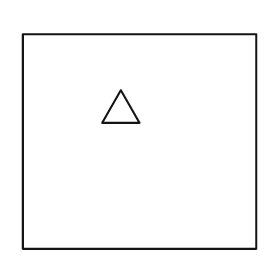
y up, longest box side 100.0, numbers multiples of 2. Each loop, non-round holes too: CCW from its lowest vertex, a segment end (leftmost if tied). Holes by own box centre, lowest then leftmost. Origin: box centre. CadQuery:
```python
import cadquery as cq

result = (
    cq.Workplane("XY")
    .moveTo(-50.0, -46.0)
    .lineTo(50.0, -46.0)
    .lineTo(50.0, 46.0)
    .lineTo(-50.0, 46.0)
    .close()
    .moveTo(-16.0, 8.0)
    .lineTo(0.0, 8.0)
    .lineTo(-8.0, 22.0)
    .close()
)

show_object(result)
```